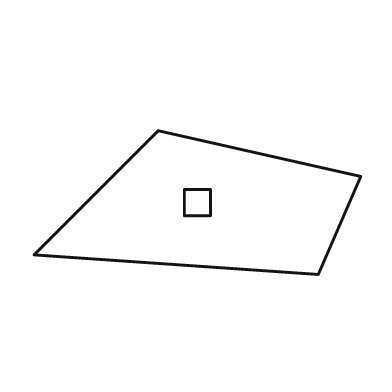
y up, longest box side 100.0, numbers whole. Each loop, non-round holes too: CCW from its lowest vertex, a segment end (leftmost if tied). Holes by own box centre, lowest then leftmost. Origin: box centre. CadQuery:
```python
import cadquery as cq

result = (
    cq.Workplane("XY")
    .moveTo(37.0, -22.0)
    .lineTo(50.0, 8.0)
    .lineTo(-12.0, 22.0)
    .lineTo(-50.0, -16.0)
    .close()
    .moveTo(-4.0, -4.0)
    .lineTo(4.0, -4.0)
    .lineTo(4.0, 4.0)
    .lineTo(-4.0, 4.0)
    .close()
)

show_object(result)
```